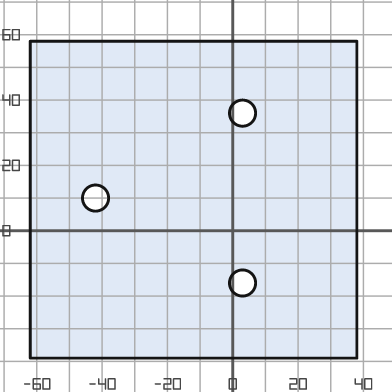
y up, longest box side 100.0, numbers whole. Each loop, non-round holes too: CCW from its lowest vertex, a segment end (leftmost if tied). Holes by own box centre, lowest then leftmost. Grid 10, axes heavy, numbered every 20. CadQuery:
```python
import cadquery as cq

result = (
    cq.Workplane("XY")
    .moveTo(-62.0, -39.0)
    .lineTo(38.0, -39.0)
    .lineTo(38.0, 58.0)
    .lineTo(-62.0, 58.0)
    .close()
    .moveTo(3.0, -16.0)
    .circle(4.0)
    .moveTo(-42.0, 10.0)
    .circle(4.0)
    .moveTo(3.0, 36.0)
    .circle(4.0)
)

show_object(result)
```